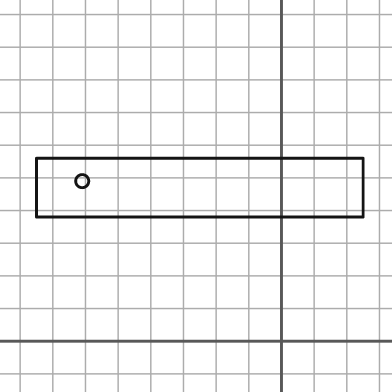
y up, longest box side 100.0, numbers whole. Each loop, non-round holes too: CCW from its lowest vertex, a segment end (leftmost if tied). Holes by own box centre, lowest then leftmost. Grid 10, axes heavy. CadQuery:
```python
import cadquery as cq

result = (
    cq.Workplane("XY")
    .moveTo(-75.0, 38.0)
    .lineTo(25.0, 38.0)
    .lineTo(25.0, 56.0)
    .lineTo(-75.0, 56.0)
    .close()
    .moveTo(-61.0, 49.0)
    .circle(2.0)
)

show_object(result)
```